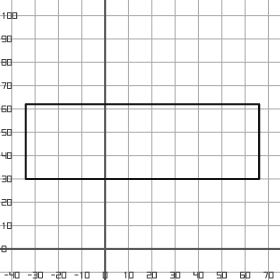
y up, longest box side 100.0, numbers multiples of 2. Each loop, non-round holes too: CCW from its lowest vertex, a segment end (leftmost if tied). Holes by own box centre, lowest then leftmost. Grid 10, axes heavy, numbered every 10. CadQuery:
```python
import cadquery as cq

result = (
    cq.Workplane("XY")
    .moveTo(-34.0, 30.0)
    .lineTo(66.0, 30.0)
    .lineTo(66.0, 62.0)
    .lineTo(-34.0, 62.0)
    .close()
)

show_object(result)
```